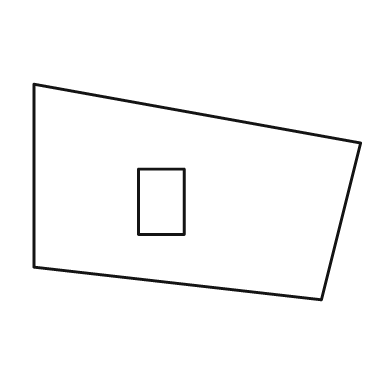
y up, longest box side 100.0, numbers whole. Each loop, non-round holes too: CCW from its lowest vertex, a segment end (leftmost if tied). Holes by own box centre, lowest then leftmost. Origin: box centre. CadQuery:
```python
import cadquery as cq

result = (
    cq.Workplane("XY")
    .moveTo(38.0, -33.0)
    .lineTo(50.0, 15.0)
    .lineTo(-50.0, 33.0)
    .lineTo(-50.0, -23.0)
    .close()
    .moveTo(-18.0, -13.0)
    .lineTo(-4.0, -13.0)
    .lineTo(-4.0, 7.0)
    .lineTo(-18.0, 7.0)
    .close()
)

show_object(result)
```